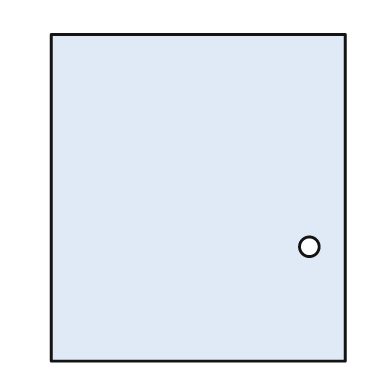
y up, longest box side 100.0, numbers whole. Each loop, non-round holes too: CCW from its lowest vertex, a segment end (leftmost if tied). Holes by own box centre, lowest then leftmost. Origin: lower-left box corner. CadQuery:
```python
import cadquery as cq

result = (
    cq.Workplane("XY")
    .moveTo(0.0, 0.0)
    .lineTo(90.0, 0.0)
    .lineTo(90.0, 100.0)
    .lineTo(0.0, 100.0)
    .close()
    .moveTo(79.0, 35.0)
    .circle(3.0)
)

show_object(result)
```